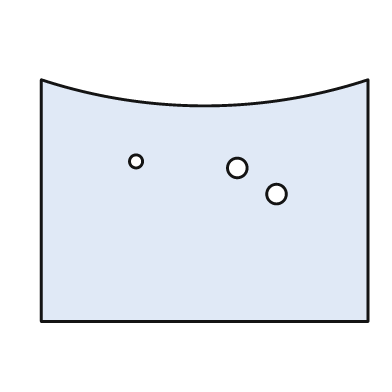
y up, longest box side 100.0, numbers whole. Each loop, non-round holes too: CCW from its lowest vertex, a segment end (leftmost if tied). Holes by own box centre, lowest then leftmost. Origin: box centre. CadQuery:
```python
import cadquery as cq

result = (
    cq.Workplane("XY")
    .moveTo(-50.0, -37.0)
    .lineTo(50.0, -37.0)
    .lineTo(50.0, 37.0)
    .threePointArc((0.0, 29.0), (-50.0, 37.0))
    .close()
    .moveTo(22.0, 2.0)
    .circle(3.0)
    .moveTo(10.0, 10.0)
    .circle(3.0)
    .moveTo(-21.0, 12.0)
    .circle(2.0)
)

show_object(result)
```